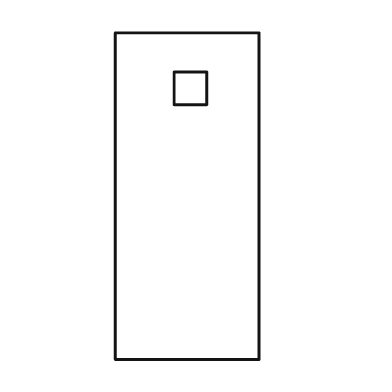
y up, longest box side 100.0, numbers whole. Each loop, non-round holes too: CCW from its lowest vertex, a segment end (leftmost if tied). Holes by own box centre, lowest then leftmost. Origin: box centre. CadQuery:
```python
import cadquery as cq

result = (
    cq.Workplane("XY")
    .moveTo(-22.0, -50.0)
    .lineTo(22.0, -50.0)
    .lineTo(22.0, 50.0)
    .lineTo(-22.0, 50.0)
    .close()
    .moveTo(-4.0, 28.0)
    .lineTo(6.0, 28.0)
    .lineTo(6.0, 38.0)
    .lineTo(-4.0, 38.0)
    .close()
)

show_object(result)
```